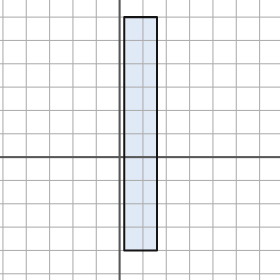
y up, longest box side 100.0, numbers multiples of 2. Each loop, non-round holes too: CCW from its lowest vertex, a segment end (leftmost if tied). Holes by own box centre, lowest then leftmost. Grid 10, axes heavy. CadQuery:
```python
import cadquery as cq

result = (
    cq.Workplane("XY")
    .moveTo(2.0, -40.0)
    .lineTo(16.0, -40.0)
    .lineTo(16.0, 60.0)
    .lineTo(2.0, 60.0)
    .close()
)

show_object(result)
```